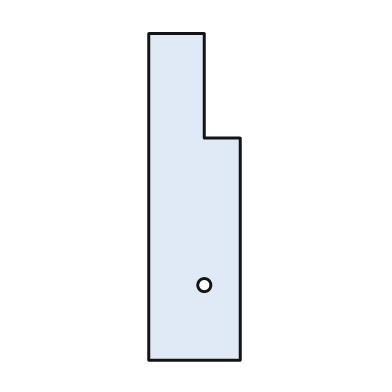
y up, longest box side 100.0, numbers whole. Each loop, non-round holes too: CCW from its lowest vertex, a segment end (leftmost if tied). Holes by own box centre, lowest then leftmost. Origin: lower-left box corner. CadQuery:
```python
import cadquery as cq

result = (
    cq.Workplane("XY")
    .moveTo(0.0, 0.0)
    .lineTo(28.0, 0.0)
    .lineTo(28.0, 68.0)
    .lineTo(17.0, 68.0)
    .lineTo(17.0, 100.0)
    .lineTo(0.0, 100.0)
    .close()
    .moveTo(17.0, 23.0)
    .circle(2.0)
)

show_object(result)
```